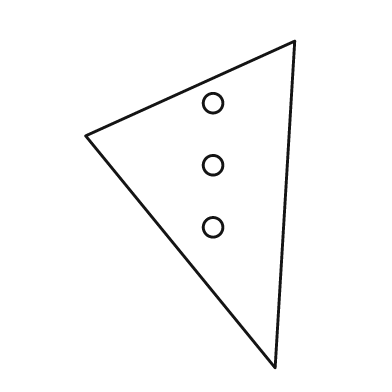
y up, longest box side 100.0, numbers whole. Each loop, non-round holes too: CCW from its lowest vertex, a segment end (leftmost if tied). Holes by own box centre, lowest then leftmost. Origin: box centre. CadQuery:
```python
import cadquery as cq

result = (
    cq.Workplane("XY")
    .moveTo(26.0, -50.0)
    .lineTo(32.0, 50.0)
    .lineTo(-32.0, 21.0)
    .close()
    .moveTo(7.0, -7.0)
    .circle(3.0)
    .moveTo(7.0, 12.0)
    .circle(3.0)
    .moveTo(7.0, 31.0)
    .circle(3.0)
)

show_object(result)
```